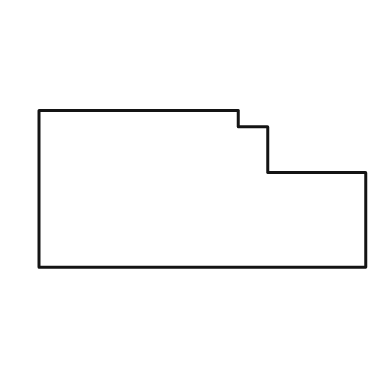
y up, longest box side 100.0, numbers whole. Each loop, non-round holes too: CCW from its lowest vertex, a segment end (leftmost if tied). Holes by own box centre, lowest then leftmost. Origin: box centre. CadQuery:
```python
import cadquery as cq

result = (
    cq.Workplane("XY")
    .moveTo(-50.0, -24.0)
    .lineTo(50.0, -24.0)
    .lineTo(50.0, 5.0)
    .lineTo(20.0, 5.0)
    .lineTo(20.0, 19.0)
    .lineTo(11.0, 19.0)
    .lineTo(11.0, 24.0)
    .lineTo(-50.0, 24.0)
    .close()
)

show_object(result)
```